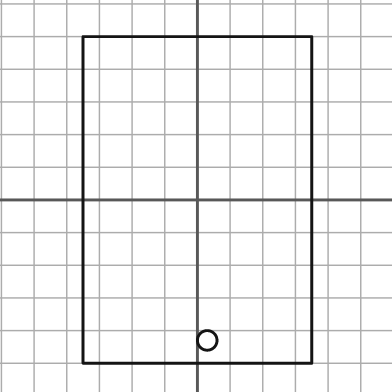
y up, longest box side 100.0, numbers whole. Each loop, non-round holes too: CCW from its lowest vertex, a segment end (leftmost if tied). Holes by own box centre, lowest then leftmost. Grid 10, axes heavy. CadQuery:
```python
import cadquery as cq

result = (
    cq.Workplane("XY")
    .moveTo(-35.0, -50.0)
    .lineTo(35.0, -50.0)
    .lineTo(35.0, 50.0)
    .lineTo(-35.0, 50.0)
    .close()
    .moveTo(3.0, -43.0)
    .circle(3.0)
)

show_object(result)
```